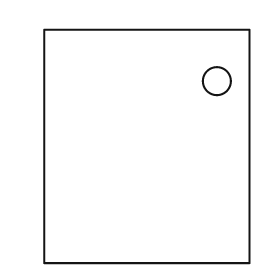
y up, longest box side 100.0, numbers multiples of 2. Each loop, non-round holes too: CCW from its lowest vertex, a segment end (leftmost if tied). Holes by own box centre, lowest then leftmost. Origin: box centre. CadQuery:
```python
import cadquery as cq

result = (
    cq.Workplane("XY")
    .moveTo(-44.0, -50.0)
    .lineTo(44.0, -50.0)
    .lineTo(44.0, 50.0)
    .lineTo(-44.0, 50.0)
    .close()
    .moveTo(30.0, 28.0)
    .circle(6.0)
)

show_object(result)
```